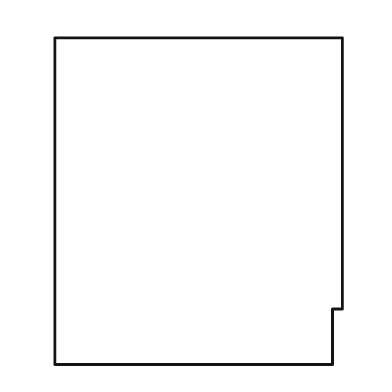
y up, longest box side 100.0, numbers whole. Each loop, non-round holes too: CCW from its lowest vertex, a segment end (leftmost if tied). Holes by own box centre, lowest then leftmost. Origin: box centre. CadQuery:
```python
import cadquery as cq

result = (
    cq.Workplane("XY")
    .moveTo(-44.0, -50.0)
    .lineTo(41.0, -50.0)
    .lineTo(41.0, -33.0)
    .lineTo(44.0, -33.0)
    .lineTo(44.0, 50.0)
    .lineTo(-44.0, 50.0)
    .close()
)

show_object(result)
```